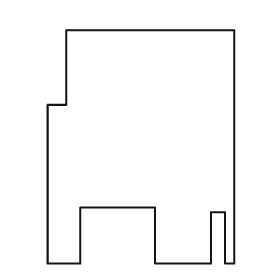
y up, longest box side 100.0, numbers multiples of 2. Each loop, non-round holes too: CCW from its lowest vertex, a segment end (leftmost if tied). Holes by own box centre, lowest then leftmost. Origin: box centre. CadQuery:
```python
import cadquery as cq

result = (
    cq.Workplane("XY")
    .moveTo(-40.0, -50.0)
    .lineTo(-26.0, -50.0)
    .lineTo(-26.0, -26.0)
    .lineTo(6.0, -26.0)
    .lineTo(6.0, -50.0)
    .lineTo(30.0, -50.0)
    .lineTo(30.0, -28.0)
    .lineTo(36.0, -28.0)
    .lineTo(36.0, -50.0)
    .lineTo(40.0, -50.0)
    .lineTo(40.0, 50.0)
    .lineTo(-32.0, 50.0)
    .lineTo(-32.0, 18.0)
    .lineTo(-40.0, 18.0)
    .close()
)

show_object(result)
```